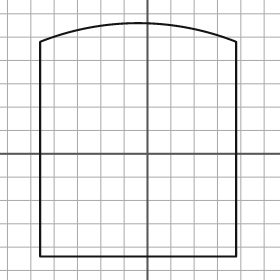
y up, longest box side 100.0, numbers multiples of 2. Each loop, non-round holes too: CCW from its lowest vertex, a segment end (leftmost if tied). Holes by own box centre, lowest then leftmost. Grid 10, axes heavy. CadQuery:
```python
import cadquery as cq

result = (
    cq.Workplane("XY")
    .moveTo(-46.0, -44.0)
    .lineTo(38.0, -44.0)
    .lineTo(38.0, 48.0)
    .threePointArc((-4.0, 56.0), (-46.0, 48.0))
    .close()
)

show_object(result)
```